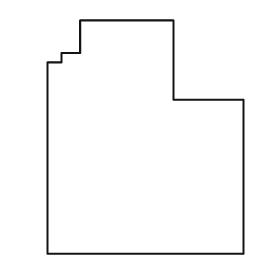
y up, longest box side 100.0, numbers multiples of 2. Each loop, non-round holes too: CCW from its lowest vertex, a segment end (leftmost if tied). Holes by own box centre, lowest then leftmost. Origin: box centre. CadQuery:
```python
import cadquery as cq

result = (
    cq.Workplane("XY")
    .moveTo(-42.0, -50.0)
    .lineTo(42.0, -50.0)
    .lineTo(42.0, 16.0)
    .lineTo(12.0, 16.0)
    .lineTo(12.0, 50.0)
    .lineTo(-28.0, 50.0)
    .lineTo(-28.0, 36.0)
    .lineTo(-36.0, 36.0)
    .lineTo(-36.0, 32.0)
    .lineTo(-42.0, 32.0)
    .close()
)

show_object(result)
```